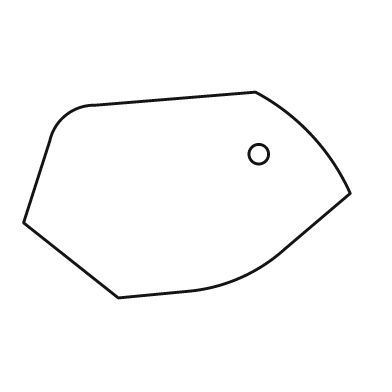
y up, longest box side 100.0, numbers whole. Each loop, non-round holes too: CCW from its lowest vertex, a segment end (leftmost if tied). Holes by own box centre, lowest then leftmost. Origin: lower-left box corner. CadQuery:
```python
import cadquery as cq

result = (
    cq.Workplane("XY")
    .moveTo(29.0, 0.0)
    .lineTo(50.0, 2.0)
    .threePointArc((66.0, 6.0), (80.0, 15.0))
    .lineTo(100.0, 32.0)
    .threePointArc((88.0, 50.0), (71.0, 63.0))
    .lineTo(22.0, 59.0)
    .threePointArc((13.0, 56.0), (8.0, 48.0))
    .lineTo(0.0, 23.0)
    .close()
    .moveTo(72.0, 44.0)
    .circle(3.0)
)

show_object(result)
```